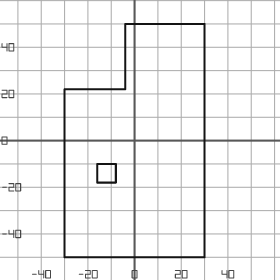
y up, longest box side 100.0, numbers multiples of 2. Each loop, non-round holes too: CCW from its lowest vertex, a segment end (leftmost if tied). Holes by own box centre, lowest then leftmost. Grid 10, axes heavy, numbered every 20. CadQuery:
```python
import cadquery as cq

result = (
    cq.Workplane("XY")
    .moveTo(-30.0, -50.0)
    .lineTo(30.0, -50.0)
    .lineTo(30.0, 50.0)
    .lineTo(-4.0, 50.0)
    .lineTo(-4.0, 22.0)
    .lineTo(-30.0, 22.0)
    .close()
    .moveTo(-16.0, -18.0)
    .lineTo(-8.0, -18.0)
    .lineTo(-8.0, -10.0)
    .lineTo(-16.0, -10.0)
    .close()
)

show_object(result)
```